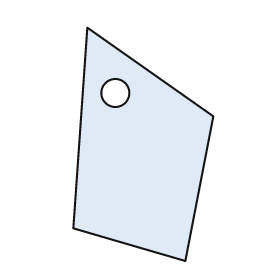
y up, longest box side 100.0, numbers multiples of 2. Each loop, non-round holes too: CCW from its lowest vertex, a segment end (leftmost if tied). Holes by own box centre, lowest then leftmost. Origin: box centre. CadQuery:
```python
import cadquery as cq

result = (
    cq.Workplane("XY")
    .moveTo(18.0, -50.0)
    .lineTo(30.0, 12.0)
    .lineTo(-24.0, 50.0)
    .lineTo(-30.0, -36.0)
    .close()
    .moveTo(-12.0, 22.0)
    .circle(6.0)
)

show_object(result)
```